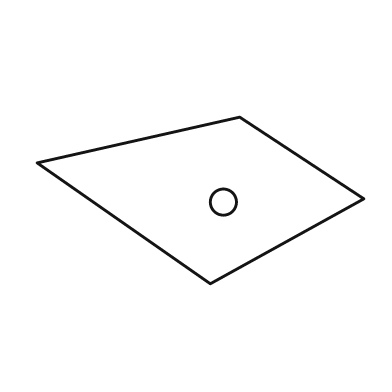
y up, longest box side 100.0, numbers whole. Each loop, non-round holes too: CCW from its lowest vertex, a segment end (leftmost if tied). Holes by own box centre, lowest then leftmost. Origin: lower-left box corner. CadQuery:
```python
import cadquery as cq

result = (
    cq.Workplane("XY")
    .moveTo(53.0, 0.0)
    .lineTo(100.0, 26.0)
    .lineTo(62.0, 51.0)
    .lineTo(0.0, 37.0)
    .close()
    .moveTo(57.0, 25.0)
    .circle(4.0)
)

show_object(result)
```